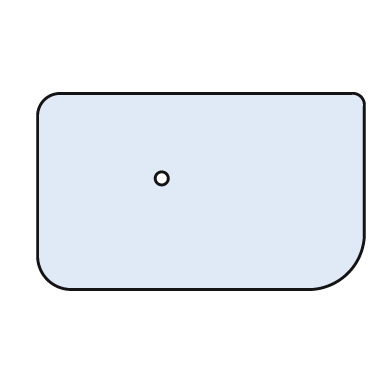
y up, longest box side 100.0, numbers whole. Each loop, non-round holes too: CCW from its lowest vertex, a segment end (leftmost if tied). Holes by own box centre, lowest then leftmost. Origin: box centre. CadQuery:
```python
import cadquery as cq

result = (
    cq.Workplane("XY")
    .moveTo(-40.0, -30.0)
    .lineTo(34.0, -30.0)
    .threePointArc((45.0, -25.0), (50.0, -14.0))
    .lineTo(50.0, 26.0)
    .threePointArc((49.0, 29.0), (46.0, 30.0))
    .lineTo(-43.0, 30.0)
    .threePointArc((-48.0, 28.0), (-50.0, 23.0))
    .lineTo(-50.0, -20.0)
    .threePointArc((-47.0, -27.0), (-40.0, -30.0))
    .close()
    .moveTo(-12.0, 4.0)
    .circle(2.0)
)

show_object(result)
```